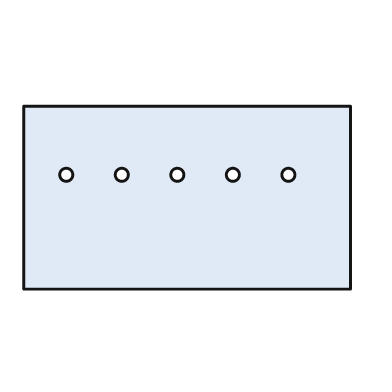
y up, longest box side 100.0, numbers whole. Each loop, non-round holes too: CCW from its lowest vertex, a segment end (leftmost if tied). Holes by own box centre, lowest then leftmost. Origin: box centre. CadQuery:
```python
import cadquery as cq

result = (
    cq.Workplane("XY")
    .moveTo(-50.0, -28.0)
    .lineTo(50.0, -28.0)
    .lineTo(50.0, 28.0)
    .lineTo(-50.0, 28.0)
    .close()
    .moveTo(-37.0, 7.0)
    .circle(2.0)
    .moveTo(-20.0, 7.0)
    .circle(2.0)
    .moveTo(-3.0, 7.0)
    .circle(2.0)
    .moveTo(14.0, 7.0)
    .circle(2.0)
    .moveTo(31.0, 7.0)
    .circle(2.0)
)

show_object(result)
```